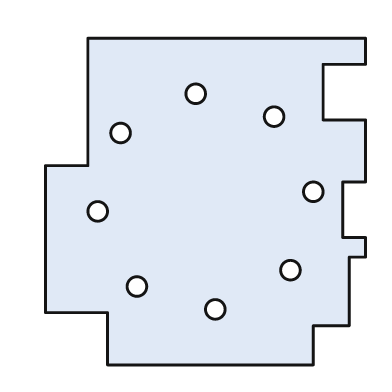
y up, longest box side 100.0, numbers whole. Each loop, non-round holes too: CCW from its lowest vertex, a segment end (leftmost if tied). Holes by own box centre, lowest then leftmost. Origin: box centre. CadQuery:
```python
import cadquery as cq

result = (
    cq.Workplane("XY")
    .moveTo(-30.0, -50.0)
    .lineTo(33.0, -50.0)
    .lineTo(33.0, -38.0)
    .lineTo(44.0, -38.0)
    .lineTo(44.0, -17.0)
    .lineTo(49.0, -17.0)
    .lineTo(49.0, -11.0)
    .lineTo(42.0, -11.0)
    .lineTo(42.0, 6.0)
    .lineTo(49.0, 6.0)
    .lineTo(49.0, 25.0)
    .lineTo(36.0, 25.0)
    .lineTo(36.0, 42.0)
    .lineTo(49.0, 42.0)
    .lineTo(49.0, 50.0)
    .lineTo(-36.0, 50.0)
    .lineTo(-36.0, 11.0)
    .lineTo(-49.0, 11.0)
    .lineTo(-49.0, -34.0)
    .lineTo(-30.0, -34.0)
    .close()
    .moveTo(3.0, -33.0)
    .circle(3.0)
    .moveTo(-21.0, -26.0)
    .circle(3.0)
    .moveTo(26.0, -21.0)
    .circle(3.0)
    .moveTo(-33.0, -3.0)
    .circle(3.0)
    .moveTo(33.0, 3.0)
    .circle(3.0)
    .moveTo(-26.0, 21.0)
    .circle(3.0)
    .moveTo(21.0, 26.0)
    .circle(3.0)
    .moveTo(-3.0, 33.0)
    .circle(3.0)
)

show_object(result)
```